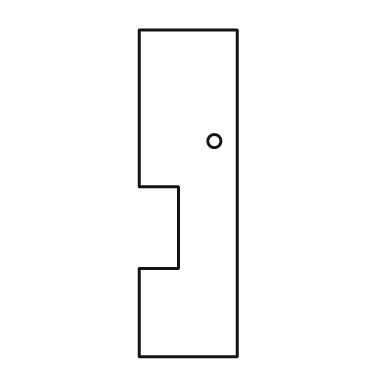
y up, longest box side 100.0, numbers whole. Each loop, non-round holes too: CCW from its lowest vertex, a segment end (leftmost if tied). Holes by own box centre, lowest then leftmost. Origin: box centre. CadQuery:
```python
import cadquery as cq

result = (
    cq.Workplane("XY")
    .moveTo(-15.0, -50.0)
    .lineTo(15.0, -50.0)
    .lineTo(15.0, 50.0)
    .lineTo(-15.0, 50.0)
    .lineTo(-15.0, 2.0)
    .lineTo(-3.0, 2.0)
    .lineTo(-3.0, -23.0)
    .lineTo(-15.0, -23.0)
    .close()
    .moveTo(8.0, 16.0)
    .circle(2.0)
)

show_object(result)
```